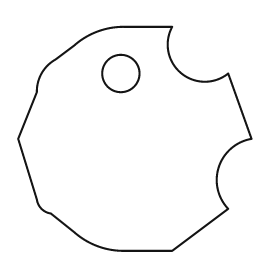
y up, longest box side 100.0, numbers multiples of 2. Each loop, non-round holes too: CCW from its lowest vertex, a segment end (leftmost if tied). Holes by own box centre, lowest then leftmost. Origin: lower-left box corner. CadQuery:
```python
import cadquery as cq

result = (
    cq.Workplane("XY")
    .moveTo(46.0, 0.0)
    .lineTo(66.0, 0.0)
    .lineTo(90.0, 18.0)
    .threePointArc((86.0, 36.0), (100.0, 48.0))
    .lineTo(90.0, 76.0)
    .threePointArc((70.0, 76.0), (66.0, 96.0))
    .lineTo(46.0, 96.0)
    .threePointArc((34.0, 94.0), (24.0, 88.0))
    .lineTo(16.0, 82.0)
    .threePointArc((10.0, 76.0), (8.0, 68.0))
    .lineTo(0.0, 48.0)
    .lineTo(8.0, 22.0)
    .threePointArc((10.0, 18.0), (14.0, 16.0))
    .lineTo(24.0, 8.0)
    .threePointArc((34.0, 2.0), (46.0, 0.0))
    .close()
    .moveTo(44.0, 76.0)
    .circle(8.0)
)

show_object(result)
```